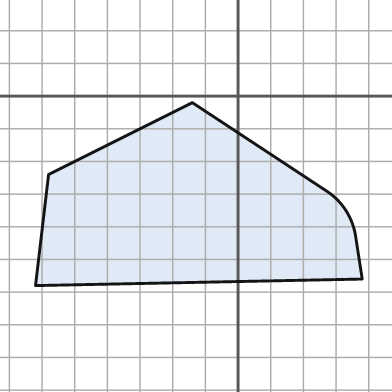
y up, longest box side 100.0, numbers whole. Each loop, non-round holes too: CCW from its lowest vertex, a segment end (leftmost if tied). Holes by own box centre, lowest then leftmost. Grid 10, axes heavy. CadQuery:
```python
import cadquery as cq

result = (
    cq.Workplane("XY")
    .moveTo(-62.0, -58.0)
    .lineTo(38.0, -56.0)
    .lineTo(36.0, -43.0)
    .threePointArc((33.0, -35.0), (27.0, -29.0))
    .lineTo(-14.0, -2.0)
    .lineTo(-58.0, -24.0)
    .close()
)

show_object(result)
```